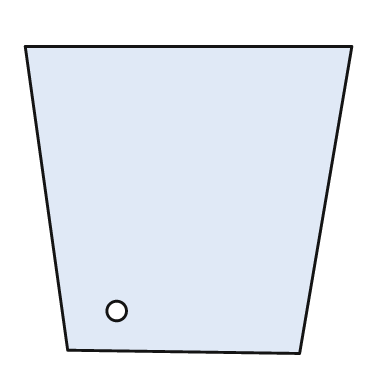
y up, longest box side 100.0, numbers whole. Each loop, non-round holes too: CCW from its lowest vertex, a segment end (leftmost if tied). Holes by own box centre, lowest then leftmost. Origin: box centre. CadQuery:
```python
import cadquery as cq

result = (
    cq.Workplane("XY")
    .moveTo(34.0, -47.0)
    .lineTo(50.0, 47.0)
    .lineTo(-50.0, 47.0)
    .lineTo(-37.0, -46.0)
    .close()
    .moveTo(-22.0, -34.0)
    .circle(3.0)
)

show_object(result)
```